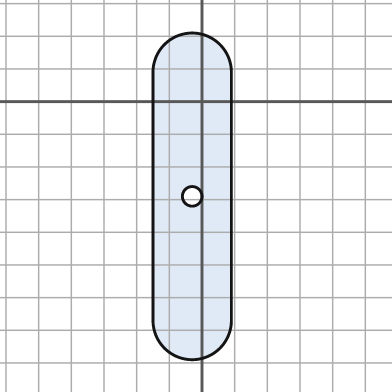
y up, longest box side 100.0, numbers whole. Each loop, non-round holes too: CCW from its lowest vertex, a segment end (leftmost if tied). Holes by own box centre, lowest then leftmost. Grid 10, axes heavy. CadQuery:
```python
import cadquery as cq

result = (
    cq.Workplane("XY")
    .moveTo(-15.0, -67.0)
    .threePointArc((-3.0, -79.0), (9.0, -67.0))
    .lineTo(9.0, 9.0)
    .threePointArc((-3.0, 21.0), (-15.0, 9.0))
    .close()
    .moveTo(-3.0, -29.0)
    .circle(3.0)
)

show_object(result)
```